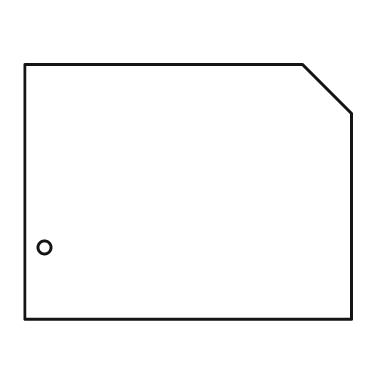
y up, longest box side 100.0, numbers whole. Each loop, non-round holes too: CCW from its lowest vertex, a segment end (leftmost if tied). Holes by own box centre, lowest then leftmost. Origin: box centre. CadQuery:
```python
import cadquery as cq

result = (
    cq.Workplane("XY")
    .moveTo(-50.0, -39.0)
    .lineTo(50.0, -39.0)
    .lineTo(50.0, 24.0)
    .lineTo(35.0, 39.0)
    .lineTo(-50.0, 39.0)
    .close()
    .moveTo(-44.0, -17.0)
    .circle(2.0)
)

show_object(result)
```